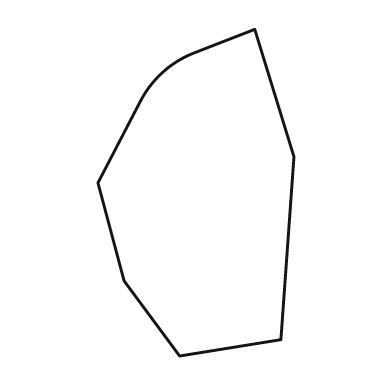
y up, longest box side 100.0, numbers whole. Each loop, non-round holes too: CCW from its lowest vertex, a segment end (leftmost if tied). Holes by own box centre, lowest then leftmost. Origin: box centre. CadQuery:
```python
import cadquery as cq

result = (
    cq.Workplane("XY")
    .moveTo(-5.0, -50.0)
    .lineTo(26.0, -45.0)
    .lineTo(30.0, 11.0)
    .lineTo(18.0, 50.0)
    .lineTo(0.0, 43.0)
    .threePointArc((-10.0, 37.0), (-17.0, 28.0))
    .lineTo(-30.0, 3.0)
    .lineTo(-22.0, -27.0)
    .close()
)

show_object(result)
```